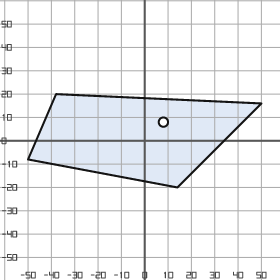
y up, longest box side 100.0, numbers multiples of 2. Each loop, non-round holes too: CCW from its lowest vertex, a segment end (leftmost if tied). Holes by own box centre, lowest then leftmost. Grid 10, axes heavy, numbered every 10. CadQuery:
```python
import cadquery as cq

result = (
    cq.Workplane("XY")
    .moveTo(14.0, -20.0)
    .lineTo(50.0, 16.0)
    .lineTo(-38.0, 20.0)
    .lineTo(-50.0, -8.0)
    .close()
    .moveTo(8.0, 8.0)
    .circle(2.0)
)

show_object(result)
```